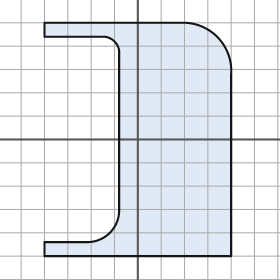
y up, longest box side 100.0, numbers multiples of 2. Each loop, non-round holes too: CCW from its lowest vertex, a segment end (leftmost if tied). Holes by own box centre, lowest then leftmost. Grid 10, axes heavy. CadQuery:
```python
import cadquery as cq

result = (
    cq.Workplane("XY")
    .moveTo(-40.0, -50.0)
    .lineTo(40.0, -50.0)
    .lineTo(40.0, 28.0)
    .threePointArc((34.0, 44.0), (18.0, 50.0))
    .lineTo(-40.0, 50.0)
    .lineTo(-40.0, 44.0)
    .lineTo(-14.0, 44.0)
    .threePointArc((-10.0, 42.0), (-8.0, 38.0))
    .lineTo(-8.0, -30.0)
    .threePointArc((-12.0, -40.0), (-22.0, -44.0))
    .lineTo(-40.0, -44.0)
    .close()
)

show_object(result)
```